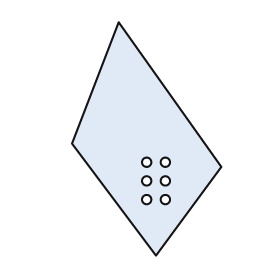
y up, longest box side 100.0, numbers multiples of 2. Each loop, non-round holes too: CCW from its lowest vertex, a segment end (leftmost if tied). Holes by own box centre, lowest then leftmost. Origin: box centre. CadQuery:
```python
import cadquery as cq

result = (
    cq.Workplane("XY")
    .moveTo(4.0, -50.0)
    .lineTo(32.0, -12.0)
    .lineTo(-12.0, 50.0)
    .lineTo(-32.0, -2.0)
    .close()
    .moveTo(0.0, -26.0)
    .circle(2.0)
    .moveTo(8.0, -26.0)
    .circle(2.0)
    .moveTo(0.0, -18.0)
    .circle(2.0)
    .moveTo(8.0, -18.0)
    .circle(2.0)
    .moveTo(0.0, -10.0)
    .circle(2.0)
    .moveTo(8.0, -10.0)
    .circle(2.0)
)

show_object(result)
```